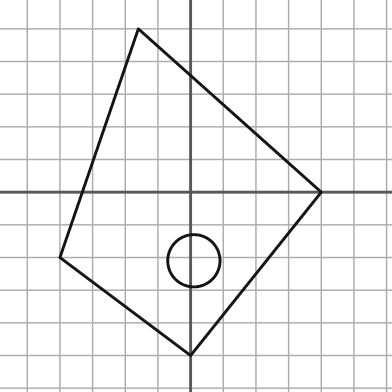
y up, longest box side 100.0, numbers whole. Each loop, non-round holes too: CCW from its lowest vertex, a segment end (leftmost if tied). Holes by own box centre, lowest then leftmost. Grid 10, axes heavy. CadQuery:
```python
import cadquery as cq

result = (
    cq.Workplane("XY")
    .moveTo(0.0, -50.0)
    .lineTo(40.0, 0.0)
    .lineTo(-16.0, 50.0)
    .lineTo(-40.0, -20.0)
    .close()
    .moveTo(1.0, -21.0)
    .circle(8.0)
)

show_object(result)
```